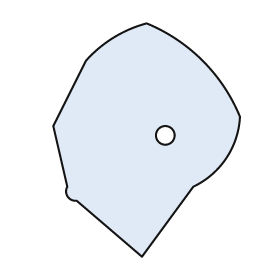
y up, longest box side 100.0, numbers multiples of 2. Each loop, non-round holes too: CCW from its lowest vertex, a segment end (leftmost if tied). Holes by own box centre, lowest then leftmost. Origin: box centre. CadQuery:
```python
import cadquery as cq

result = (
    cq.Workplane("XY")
    .moveTo(-2.0, -50.0)
    .lineTo(20.0, -20.0)
    .threePointArc((34.0, -8.0), (40.0, 10.0))
    .threePointArc((24.0, 34.0), (0.0, 50.0))
    .threePointArc((-14.0, 44.0), (-26.0, 34.0))
    .lineTo(-40.0, 6.0)
    .lineTo(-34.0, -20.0)
    .threePointArc((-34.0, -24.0), (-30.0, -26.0))
    .close()
    .moveTo(8.0, 2.0)
    .circle(4.0)
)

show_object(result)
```